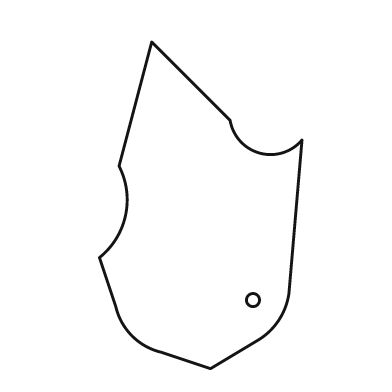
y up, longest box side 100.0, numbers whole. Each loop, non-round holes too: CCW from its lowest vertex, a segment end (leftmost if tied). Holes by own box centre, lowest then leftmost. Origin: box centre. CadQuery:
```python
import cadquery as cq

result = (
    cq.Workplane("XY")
    .moveTo(3.0, -50.0)
    .lineTo(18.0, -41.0)
    .threePointArc((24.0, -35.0), (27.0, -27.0))
    .lineTo(31.0, 20.0)
    .threePointArc((18.0, 16.0), (9.0, 26.0))
    .lineTo(-15.0, 50.0)
    .lineTo(-25.0, 12.0)
    .threePointArc((-23.0, -3.0), (-31.0, -16.0))
    .lineTo(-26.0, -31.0)
    .threePointArc((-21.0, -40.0), (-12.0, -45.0))
    .close()
    .moveTo(16.0, -29.0)
    .circle(2.0)
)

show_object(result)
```